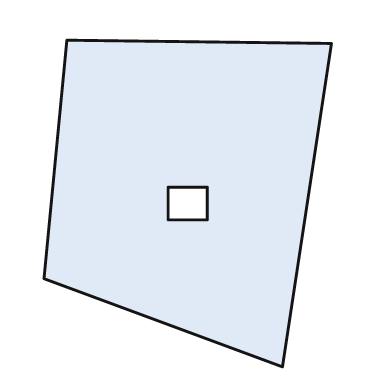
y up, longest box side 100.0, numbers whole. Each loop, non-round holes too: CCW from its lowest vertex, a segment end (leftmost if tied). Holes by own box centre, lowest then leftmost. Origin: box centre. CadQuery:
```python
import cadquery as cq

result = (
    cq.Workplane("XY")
    .moveTo(29.0, -50.0)
    .lineTo(44.0, 49.0)
    .lineTo(-37.0, 50.0)
    .lineTo(-44.0, -23.0)
    .close()
    .moveTo(-6.0, -5.0)
    .lineTo(6.0, -5.0)
    .lineTo(6.0, 5.0)
    .lineTo(-6.0, 5.0)
    .close()
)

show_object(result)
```